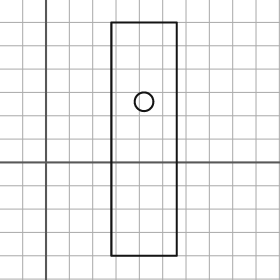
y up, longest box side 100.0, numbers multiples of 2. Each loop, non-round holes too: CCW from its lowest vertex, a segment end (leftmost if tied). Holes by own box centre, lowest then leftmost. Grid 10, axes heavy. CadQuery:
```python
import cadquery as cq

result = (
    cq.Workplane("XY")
    .moveTo(28.0, -40.0)
    .lineTo(56.0, -40.0)
    .lineTo(56.0, 60.0)
    .lineTo(28.0, 60.0)
    .close()
    .moveTo(42.0, 26.0)
    .circle(4.0)
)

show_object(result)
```